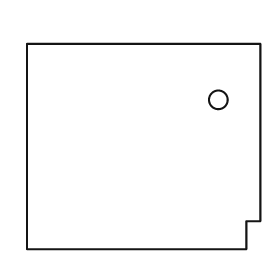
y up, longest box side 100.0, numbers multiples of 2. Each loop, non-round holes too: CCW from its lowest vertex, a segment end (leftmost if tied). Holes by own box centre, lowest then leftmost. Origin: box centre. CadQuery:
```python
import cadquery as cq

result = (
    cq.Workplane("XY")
    .moveTo(-50.0, -44.0)
    .lineTo(44.0, -44.0)
    .lineTo(44.0, -32.0)
    .lineTo(50.0, -32.0)
    .lineTo(50.0, 44.0)
    .lineTo(-50.0, 44.0)
    .close()
    .moveTo(32.0, 20.0)
    .circle(4.0)
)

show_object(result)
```